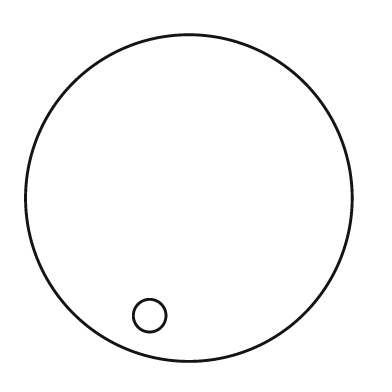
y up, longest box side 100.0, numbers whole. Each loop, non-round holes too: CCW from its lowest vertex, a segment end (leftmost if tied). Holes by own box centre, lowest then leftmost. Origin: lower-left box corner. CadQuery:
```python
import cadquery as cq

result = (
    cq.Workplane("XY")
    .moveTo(50.0, 50.0)
    .circle(50.0)
    .moveTo(38.0, 14.0)
    .circle(5.0)
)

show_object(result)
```